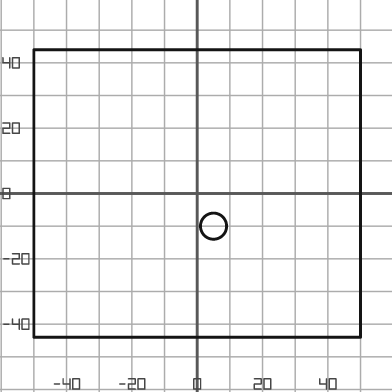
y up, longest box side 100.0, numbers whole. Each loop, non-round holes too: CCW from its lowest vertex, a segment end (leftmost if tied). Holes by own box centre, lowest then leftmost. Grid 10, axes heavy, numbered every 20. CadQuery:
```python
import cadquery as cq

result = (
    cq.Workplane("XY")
    .moveTo(-50.0, -44.0)
    .lineTo(50.0, -44.0)
    .lineTo(50.0, 44.0)
    .lineTo(-50.0, 44.0)
    .close()
    .moveTo(5.0, -10.0)
    .circle(4.0)
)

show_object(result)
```